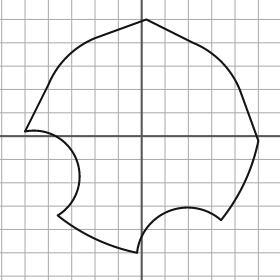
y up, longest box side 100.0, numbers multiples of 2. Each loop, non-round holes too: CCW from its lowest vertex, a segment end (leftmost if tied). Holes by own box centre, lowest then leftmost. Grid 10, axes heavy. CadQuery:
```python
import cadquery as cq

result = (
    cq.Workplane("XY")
    .moveTo(-2.0, -50.0)
    .threePointArc((12.0, -32.0), (34.0, -36.0))
    .threePointArc((44.0, -20.0), (50.0, -2.0))
    .lineTo(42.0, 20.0)
    .threePointArc((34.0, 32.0), (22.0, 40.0))
    .lineTo(2.0, 50.0)
    .lineTo(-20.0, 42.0)
    .threePointArc((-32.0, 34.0), (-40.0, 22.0))
    .lineTo(-50.0, 2.0)
    .threePointArc((-28.0, -10.0), (-36.0, -34.0))
    .threePointArc((-20.0, -44.0), (-2.0, -50.0))
    .close()
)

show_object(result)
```